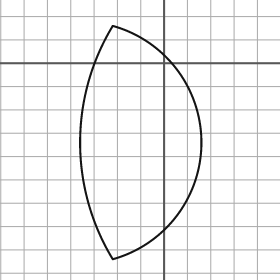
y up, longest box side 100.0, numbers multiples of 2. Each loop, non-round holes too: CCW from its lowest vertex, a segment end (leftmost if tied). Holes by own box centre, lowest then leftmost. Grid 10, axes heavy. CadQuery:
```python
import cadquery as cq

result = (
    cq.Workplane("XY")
    .moveTo(-22.0, -84.0)
    .threePointArc((16.0, -34.0), (-22.0, 16.0))
    .threePointArc((-36.0, -34.0), (-22.0, -84.0))
    .close()
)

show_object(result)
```